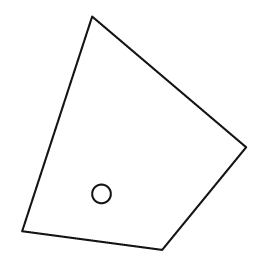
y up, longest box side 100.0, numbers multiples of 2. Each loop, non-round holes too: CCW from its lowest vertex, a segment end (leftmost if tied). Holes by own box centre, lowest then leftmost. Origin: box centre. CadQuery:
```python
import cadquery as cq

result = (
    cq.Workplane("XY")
    .moveTo(12.0, -50.0)
    .lineTo(48.0, -6.0)
    .lineTo(-18.0, 50.0)
    .lineTo(-48.0, -42.0)
    .close()
    .moveTo(-14.0, -26.0)
    .circle(4.0)
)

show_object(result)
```